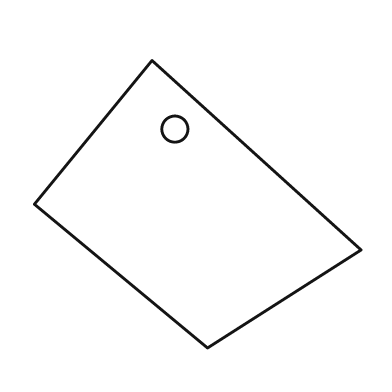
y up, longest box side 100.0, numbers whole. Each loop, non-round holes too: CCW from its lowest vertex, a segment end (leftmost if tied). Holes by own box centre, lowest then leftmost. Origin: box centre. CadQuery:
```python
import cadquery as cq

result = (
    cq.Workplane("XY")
    .moveTo(3.0, -44.0)
    .lineTo(50.0, -14.0)
    .lineTo(-14.0, 44.0)
    .lineTo(-50.0, 0.0)
    .close()
    .moveTo(-7.0, 23.0)
    .circle(4.0)
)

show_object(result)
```